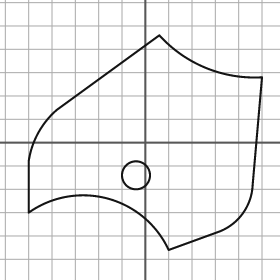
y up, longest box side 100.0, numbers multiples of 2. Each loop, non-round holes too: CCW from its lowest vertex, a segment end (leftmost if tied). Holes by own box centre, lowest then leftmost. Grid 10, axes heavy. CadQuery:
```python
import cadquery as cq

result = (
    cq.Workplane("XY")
    .moveTo(10.0, -46.0)
    .lineTo(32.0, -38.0)
    .threePointArc((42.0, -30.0), (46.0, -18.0))
    .lineTo(50.0, 28.0)
    .threePointArc((26.0, 32.0), (6.0, 46.0))
    .lineTo(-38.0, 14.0)
    .threePointArc((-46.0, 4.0), (-50.0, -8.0))
    .lineTo(-50.0, -30.0)
    .threePointArc((-16.0, -24.0), (10.0, -46.0))
    .close()
    .moveTo(-4.0, -14.0)
    .circle(6.0)
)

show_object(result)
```